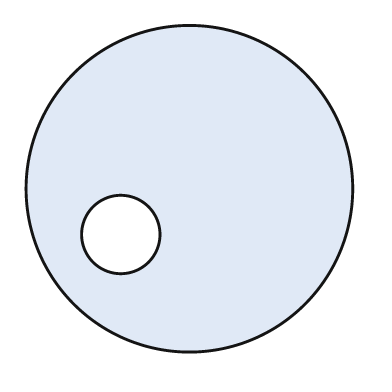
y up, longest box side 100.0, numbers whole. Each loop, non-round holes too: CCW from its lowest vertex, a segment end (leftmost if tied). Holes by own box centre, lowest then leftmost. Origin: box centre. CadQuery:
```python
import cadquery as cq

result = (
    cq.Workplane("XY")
    .moveTo(0.0, 0.0)
    .circle(50.0)
    .moveTo(-21.0, -14.0)
    .circle(12.0)
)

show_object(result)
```